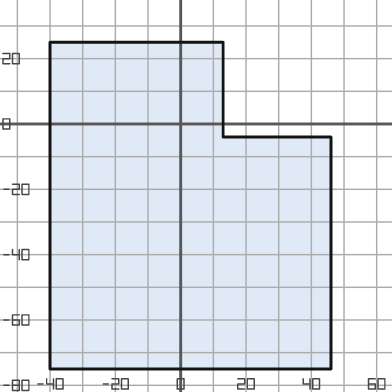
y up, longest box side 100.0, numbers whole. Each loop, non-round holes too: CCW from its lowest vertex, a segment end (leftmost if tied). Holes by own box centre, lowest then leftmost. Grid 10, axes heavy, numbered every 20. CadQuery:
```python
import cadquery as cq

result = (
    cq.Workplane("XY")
    .moveTo(-40.0, -75.0)
    .lineTo(46.0, -75.0)
    .lineTo(46.0, -4.0)
    .lineTo(13.0, -4.0)
    .lineTo(13.0, 25.0)
    .lineTo(-40.0, 25.0)
    .close()
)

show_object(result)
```